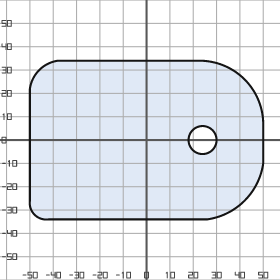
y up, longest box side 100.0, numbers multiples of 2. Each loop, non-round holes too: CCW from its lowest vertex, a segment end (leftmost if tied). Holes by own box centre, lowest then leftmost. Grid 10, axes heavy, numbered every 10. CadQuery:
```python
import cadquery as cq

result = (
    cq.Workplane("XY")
    .moveTo(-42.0, -34.0)
    .lineTo(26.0, -34.0)
    .threePointArc((42.0, -26.0), (50.0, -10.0))
    .lineTo(50.0, 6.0)
    .threePointArc((42.0, 26.0), (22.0, 34.0))
    .lineTo(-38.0, 34.0)
    .threePointArc((-46.0, 30.0), (-50.0, 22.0))
    .lineTo(-50.0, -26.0)
    .threePointArc((-48.0, -32.0), (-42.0, -34.0))
    .close()
    .moveTo(24.0, 0.0)
    .circle(6.0)
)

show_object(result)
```